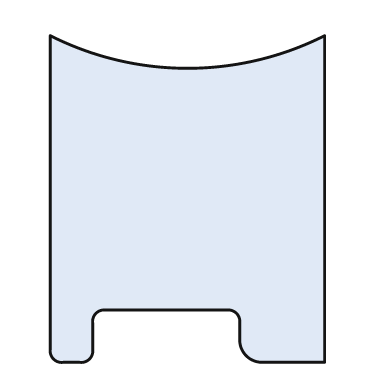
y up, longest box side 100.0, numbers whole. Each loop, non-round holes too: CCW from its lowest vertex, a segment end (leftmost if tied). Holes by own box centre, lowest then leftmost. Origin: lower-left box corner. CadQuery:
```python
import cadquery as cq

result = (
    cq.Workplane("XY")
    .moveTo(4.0, 0.0)
    .lineTo(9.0, 0.0)
    .threePointArc((12.0, 1.0), (13.0, 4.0))
    .lineTo(13.0, 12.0)
    .threePointArc((14.0, 15.0), (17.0, 16.0))
    .lineTo(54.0, 16.0)
    .threePointArc((57.0, 15.0), (58.0, 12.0))
    .lineTo(58.0, 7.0)
    .threePointArc((60.0, 2.0), (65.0, 0.0))
    .lineTo(84.0, 0.0)
    .lineTo(84.0, 100.0)
    .threePointArc((42.0, 90.0), (0.0, 100.0))
    .lineTo(0.0, 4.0)
    .threePointArc((1.0, 1.0), (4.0, 0.0))
    .close()
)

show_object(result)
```